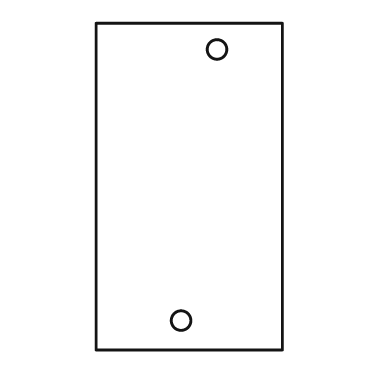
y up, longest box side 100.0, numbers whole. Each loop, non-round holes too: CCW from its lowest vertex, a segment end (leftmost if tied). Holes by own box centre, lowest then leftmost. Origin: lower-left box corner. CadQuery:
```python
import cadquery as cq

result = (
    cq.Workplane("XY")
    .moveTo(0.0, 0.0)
    .lineTo(57.0, 0.0)
    .lineTo(57.0, 100.0)
    .lineTo(0.0, 100.0)
    .close()
    .moveTo(26.0, 9.0)
    .circle(3.0)
    .moveTo(37.0, 92.0)
    .circle(3.0)
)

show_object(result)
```